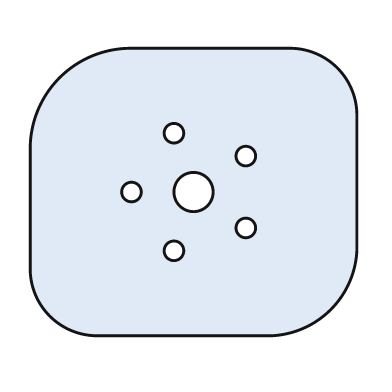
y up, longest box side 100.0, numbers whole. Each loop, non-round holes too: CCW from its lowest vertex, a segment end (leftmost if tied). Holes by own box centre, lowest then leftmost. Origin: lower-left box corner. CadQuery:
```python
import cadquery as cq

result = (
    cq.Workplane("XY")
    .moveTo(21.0, 0.0)
    .lineTo(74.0, 0.0)
    .threePointArc((92.0, 8.0), (100.0, 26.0))
    .lineTo(100.0, 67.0)
    .threePointArc((94.0, 82.0), (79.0, 88.0))
    .lineTo(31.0, 88.0)
    .threePointArc((9.0, 79.0), (0.0, 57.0))
    .lineTo(0.0, 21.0)
    .threePointArc((6.0, 6.0), (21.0, 0.0))
    .close()
    .moveTo(44.0, 26.0)
    .circle(3.0)
    .moveTo(66.0, 33.0)
    .circle(3.0)
    .moveTo(31.0, 44.0)
    .circle(3.0)
    .moveTo(50.0, 44.0)
    .circle(6.0)
    .moveTo(66.0, 55.0)
    .circle(3.0)
    .moveTo(44.0, 62.0)
    .circle(3.0)
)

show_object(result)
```